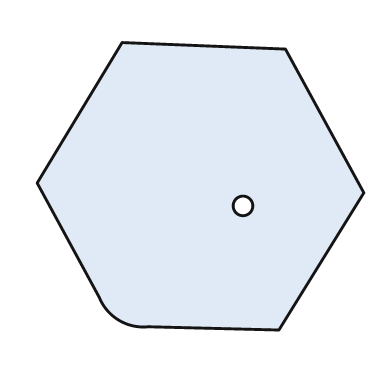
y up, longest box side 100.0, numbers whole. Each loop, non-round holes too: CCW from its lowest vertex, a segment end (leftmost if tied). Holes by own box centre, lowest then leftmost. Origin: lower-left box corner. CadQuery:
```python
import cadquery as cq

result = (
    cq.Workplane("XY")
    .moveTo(74.0, 0.0)
    .lineTo(100.0, 42.0)
    .lineTo(76.0, 86.0)
    .lineTo(26.0, 88.0)
    .lineTo(0.0, 45.0)
    .lineTo(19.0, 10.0)
    .threePointArc((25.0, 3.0), (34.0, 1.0))
    .close()
    .moveTo(63.0, 38.0)
    .circle(3.0)
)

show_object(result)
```